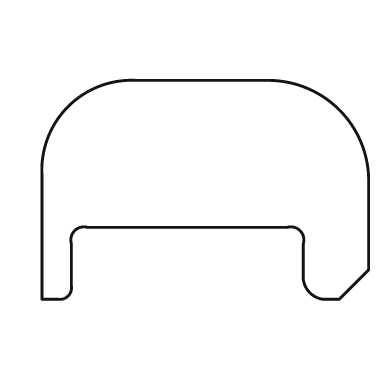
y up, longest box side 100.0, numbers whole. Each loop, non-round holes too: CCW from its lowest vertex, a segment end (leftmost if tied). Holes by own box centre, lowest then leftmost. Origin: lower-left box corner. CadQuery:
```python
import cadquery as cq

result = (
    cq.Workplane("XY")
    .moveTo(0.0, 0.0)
    .lineTo(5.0, 0.0)
    .threePointArc((8.0, 1.0), (9.0, 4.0))
    .lineTo(9.0, 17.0)
    .threePointArc((10.0, 21.0), (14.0, 22.0))
    .lineTo(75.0, 22.0)
    .threePointArc((79.0, 21.0), (80.0, 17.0))
    .lineTo(80.0, 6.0)
    .threePointArc((82.0, 2.0), (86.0, 0.0))
    .lineTo(91.0, 0.0)
    .lineTo(100.0, 9.0)
    .lineTo(100.0, 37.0)
    .threePointArc((91.0, 58.0), (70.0, 67.0))
    .lineTo(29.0, 67.0)
    .threePointArc((8.0, 59.0), (0.0, 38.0))
    .close()
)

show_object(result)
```